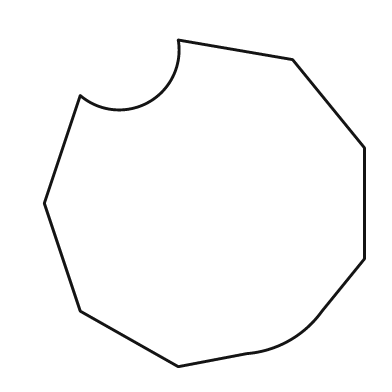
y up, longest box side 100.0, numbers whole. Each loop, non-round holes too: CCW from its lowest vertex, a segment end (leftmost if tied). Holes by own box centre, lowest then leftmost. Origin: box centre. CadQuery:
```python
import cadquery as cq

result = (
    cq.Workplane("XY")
    .moveTo(-8.0, -50.0)
    .lineTo(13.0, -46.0)
    .threePointArc((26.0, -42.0), (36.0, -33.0))
    .lineTo(49.0, -17.0)
    .lineTo(49.0, 17.0)
    .lineTo(27.0, 44.0)
    .lineTo(-8.0, 50.0)
    .threePointArc((-17.0, 31.0), (-38.0, 33.0))
    .lineTo(-49.0, 0.0)
    .lineTo(-38.0, -33.0)
    .close()
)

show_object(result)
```